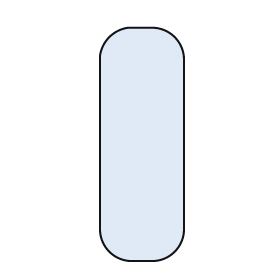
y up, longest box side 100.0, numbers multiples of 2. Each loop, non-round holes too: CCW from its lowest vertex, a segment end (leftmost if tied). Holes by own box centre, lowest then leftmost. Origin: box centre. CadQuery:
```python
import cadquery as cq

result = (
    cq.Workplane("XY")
    .moveTo(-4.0, -50.0)
    .lineTo(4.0, -50.0)
    .threePointArc((14.0, -46.0), (18.0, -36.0))
    .lineTo(18.0, 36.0)
    .threePointArc((14.0, 46.0), (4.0, 50.0))
    .lineTo(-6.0, 50.0)
    .threePointArc((-14.0, 46.0), (-18.0, 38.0))
    .lineTo(-18.0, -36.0)
    .threePointArc((-14.0, -46.0), (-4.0, -50.0))
    .close()
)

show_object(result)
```